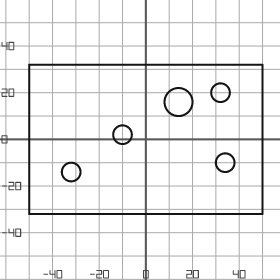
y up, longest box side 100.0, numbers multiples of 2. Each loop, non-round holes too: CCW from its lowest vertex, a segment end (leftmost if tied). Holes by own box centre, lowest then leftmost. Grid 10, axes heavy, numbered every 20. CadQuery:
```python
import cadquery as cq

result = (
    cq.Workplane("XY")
    .moveTo(-50.0, -32.0)
    .lineTo(50.0, -32.0)
    .lineTo(50.0, 32.0)
    .lineTo(-50.0, 32.0)
    .close()
    .moveTo(-32.0, -14.0)
    .circle(4.0)
    .moveTo(34.0, -10.0)
    .circle(4.0)
    .moveTo(-10.0, 2.0)
    .circle(4.0)
    .moveTo(14.0, 16.0)
    .circle(6.0)
    .moveTo(32.0, 20.0)
    .circle(4.0)
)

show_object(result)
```